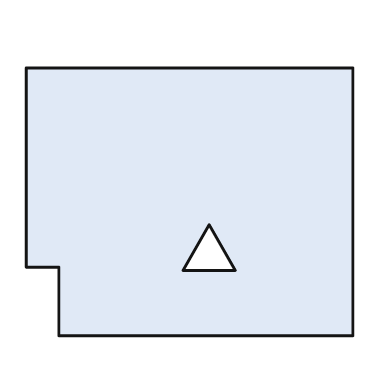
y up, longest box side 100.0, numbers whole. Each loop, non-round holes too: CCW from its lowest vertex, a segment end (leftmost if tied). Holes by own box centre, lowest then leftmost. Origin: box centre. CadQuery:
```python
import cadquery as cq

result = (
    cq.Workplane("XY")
    .moveTo(-40.0, -41.0)
    .lineTo(50.0, -41.0)
    .lineTo(50.0, 41.0)
    .lineTo(-50.0, 41.0)
    .lineTo(-50.0, -20.0)
    .lineTo(-40.0, -20.0)
    .close()
    .moveTo(-2.0, -21.0)
    .lineTo(14.0, -21.0)
    .lineTo(6.0, -7.0)
    .close()
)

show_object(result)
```